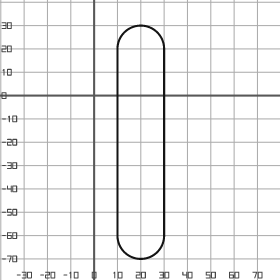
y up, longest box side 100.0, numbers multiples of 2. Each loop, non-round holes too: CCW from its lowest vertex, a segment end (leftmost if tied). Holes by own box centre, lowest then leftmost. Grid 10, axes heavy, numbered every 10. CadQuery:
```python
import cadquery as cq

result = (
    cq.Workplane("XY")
    .moveTo(10.0, -60.0)
    .threePointArc((20.0, -70.0), (30.0, -60.0))
    .lineTo(30.0, 20.0)
    .threePointArc((20.0, 30.0), (10.0, 20.0))
    .close()
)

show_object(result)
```